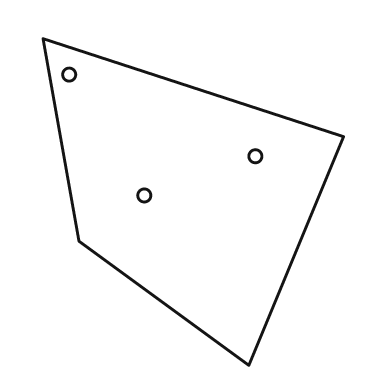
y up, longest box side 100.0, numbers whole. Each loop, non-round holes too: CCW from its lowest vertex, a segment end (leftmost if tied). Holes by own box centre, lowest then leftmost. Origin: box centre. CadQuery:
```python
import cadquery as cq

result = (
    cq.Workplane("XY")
    .moveTo(17.0, -50.0)
    .lineTo(46.0, 20.0)
    .lineTo(-46.0, 50.0)
    .lineTo(-35.0, -12.0)
    .close()
    .moveTo(-15.0, 2.0)
    .circle(2.0)
    .moveTo(19.0, 14.0)
    .circle(2.0)
    .moveTo(-38.0, 39.0)
    .circle(2.0)
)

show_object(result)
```